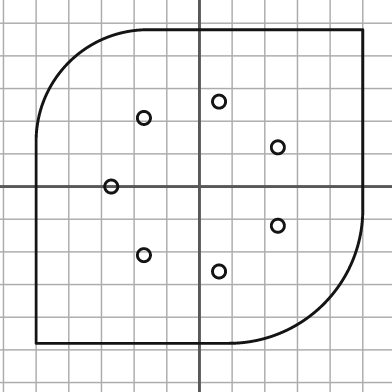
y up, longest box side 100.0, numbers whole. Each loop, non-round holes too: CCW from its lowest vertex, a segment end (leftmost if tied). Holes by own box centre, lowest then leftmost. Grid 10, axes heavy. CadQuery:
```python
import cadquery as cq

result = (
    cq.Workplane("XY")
    .moveTo(-50.0, -48.0)
    .lineTo(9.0, -48.0)
    .threePointArc((38.0, -36.0), (50.0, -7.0))
    .lineTo(50.0, 48.0)
    .lineTo(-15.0, 48.0)
    .threePointArc((-40.0, 38.0), (-50.0, 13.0))
    .close()
    .moveTo(6.0, -26.0)
    .circle(2.0)
    .moveTo(-17.0, -21.0)
    .circle(2.0)
    .moveTo(24.0, -12.0)
    .circle(2.0)
    .moveTo(-27.0, 0.0)
    .circle(2.0)
    .moveTo(24.0, 12.0)
    .circle(2.0)
    .moveTo(-17.0, 21.0)
    .circle(2.0)
    .moveTo(6.0, 26.0)
    .circle(2.0)
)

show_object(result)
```